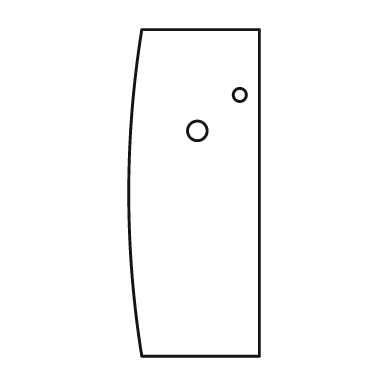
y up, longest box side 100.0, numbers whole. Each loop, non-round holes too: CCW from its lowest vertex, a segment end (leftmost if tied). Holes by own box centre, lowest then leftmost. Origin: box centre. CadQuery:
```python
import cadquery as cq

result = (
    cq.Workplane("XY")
    .moveTo(-16.0, -50.0)
    .lineTo(20.0, -50.0)
    .lineTo(20.0, 50.0)
    .lineTo(-16.0, 50.0)
    .threePointArc((-20.0, 0.0), (-16.0, -50.0))
    .close()
    .moveTo(1.0, 19.0)
    .circle(3.0)
    .moveTo(14.0, 30.0)
    .circle(2.0)
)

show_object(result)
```